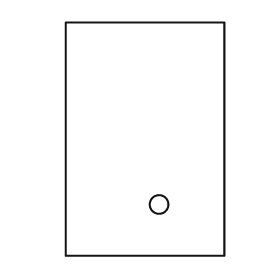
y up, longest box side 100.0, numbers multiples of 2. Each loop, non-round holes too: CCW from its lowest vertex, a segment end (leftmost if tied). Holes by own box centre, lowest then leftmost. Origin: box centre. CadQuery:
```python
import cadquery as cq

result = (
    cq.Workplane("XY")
    .moveTo(-34.0, -50.0)
    .lineTo(34.0, -50.0)
    .lineTo(34.0, 50.0)
    .lineTo(-34.0, 50.0)
    .close()
    .moveTo(6.0, -28.0)
    .circle(4.0)
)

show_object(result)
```